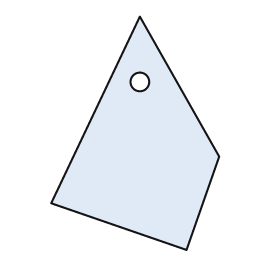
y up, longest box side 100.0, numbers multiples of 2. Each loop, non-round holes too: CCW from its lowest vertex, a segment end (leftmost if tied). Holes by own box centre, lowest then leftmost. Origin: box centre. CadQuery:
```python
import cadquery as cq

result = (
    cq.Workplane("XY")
    .moveTo(22.0, -50.0)
    .lineTo(36.0, -10.0)
    .lineTo(2.0, 50.0)
    .lineTo(-36.0, -30.0)
    .close()
    .moveTo(2.0, 22.0)
    .circle(4.0)
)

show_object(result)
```